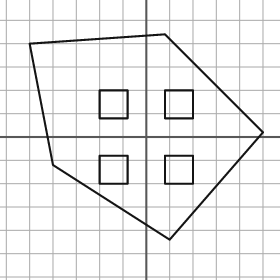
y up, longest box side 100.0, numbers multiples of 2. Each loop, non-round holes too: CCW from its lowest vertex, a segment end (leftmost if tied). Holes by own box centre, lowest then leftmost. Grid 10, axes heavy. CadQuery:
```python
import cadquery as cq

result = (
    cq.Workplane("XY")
    .moveTo(10.0, -44.0)
    .lineTo(50.0, 2.0)
    .lineTo(8.0, 44.0)
    .lineTo(-50.0, 40.0)
    .lineTo(-40.0, -12.0)
    .close()
    .moveTo(-20.0, -20.0)
    .lineTo(-8.0, -20.0)
    .lineTo(-8.0, -8.0)
    .lineTo(-20.0, -8.0)
    .close()
    .moveTo(8.0, -20.0)
    .lineTo(20.0, -20.0)
    .lineTo(20.0, -8.0)
    .lineTo(8.0, -8.0)
    .close()
    .moveTo(-20.0, 8.0)
    .lineTo(-8.0, 8.0)
    .lineTo(-8.0, 20.0)
    .lineTo(-20.0, 20.0)
    .close()
    .moveTo(8.0, 8.0)
    .lineTo(20.0, 8.0)
    .lineTo(20.0, 20.0)
    .lineTo(8.0, 20.0)
    .close()
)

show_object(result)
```